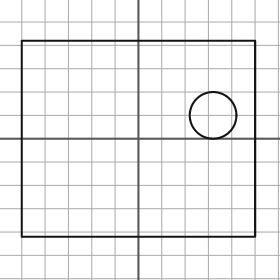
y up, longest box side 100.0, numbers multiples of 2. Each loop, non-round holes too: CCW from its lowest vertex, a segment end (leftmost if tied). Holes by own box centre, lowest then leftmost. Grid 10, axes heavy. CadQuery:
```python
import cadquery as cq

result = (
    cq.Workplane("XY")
    .moveTo(-50.0, -42.0)
    .lineTo(50.0, -42.0)
    .lineTo(50.0, 42.0)
    .lineTo(-50.0, 42.0)
    .close()
    .moveTo(32.0, 10.0)
    .circle(10.0)
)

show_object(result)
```